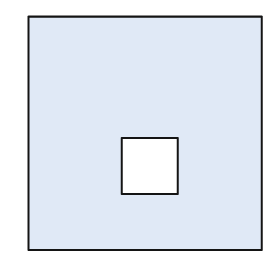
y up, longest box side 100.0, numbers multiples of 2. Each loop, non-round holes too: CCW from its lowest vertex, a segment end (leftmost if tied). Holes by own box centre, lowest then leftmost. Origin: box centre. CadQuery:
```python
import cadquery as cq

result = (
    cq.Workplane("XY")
    .moveTo(-50.0, -50.0)
    .lineTo(50.0, -50.0)
    .lineTo(50.0, 50.0)
    .lineTo(-50.0, 50.0)
    .close()
    .moveTo(-10.0, -26.0)
    .lineTo(14.0, -26.0)
    .lineTo(14.0, -2.0)
    .lineTo(-10.0, -2.0)
    .close()
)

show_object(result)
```